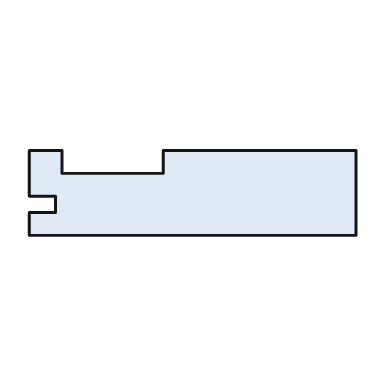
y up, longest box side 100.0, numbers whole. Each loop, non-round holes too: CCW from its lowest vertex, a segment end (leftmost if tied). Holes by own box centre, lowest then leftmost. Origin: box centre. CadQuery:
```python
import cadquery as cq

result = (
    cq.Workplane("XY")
    .moveTo(-50.0, -13.0)
    .lineTo(50.0, -13.0)
    .lineTo(50.0, 13.0)
    .lineTo(-9.0, 13.0)
    .lineTo(-9.0, 6.0)
    .lineTo(-40.0, 6.0)
    .lineTo(-40.0, 13.0)
    .lineTo(-50.0, 13.0)
    .lineTo(-50.0, -1.0)
    .lineTo(-42.0, -1.0)
    .lineTo(-42.0, -6.0)
    .lineTo(-50.0, -6.0)
    .close()
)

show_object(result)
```